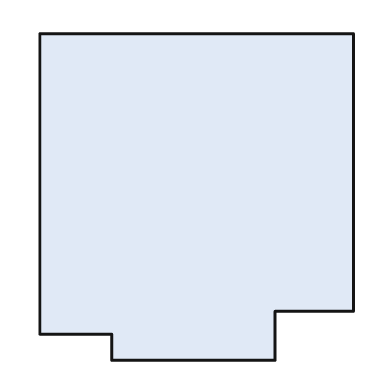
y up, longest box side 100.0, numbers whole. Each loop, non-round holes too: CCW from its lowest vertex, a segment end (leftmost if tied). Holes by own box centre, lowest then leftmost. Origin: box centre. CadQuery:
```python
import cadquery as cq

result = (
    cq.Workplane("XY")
    .moveTo(-26.0, -50.0)
    .lineTo(24.0, -50.0)
    .lineTo(24.0, -35.0)
    .lineTo(48.0, -35.0)
    .lineTo(48.0, 50.0)
    .lineTo(-48.0, 50.0)
    .lineTo(-48.0, -42.0)
    .lineTo(-26.0, -42.0)
    .close()
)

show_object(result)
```